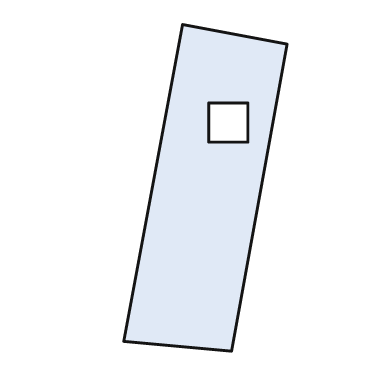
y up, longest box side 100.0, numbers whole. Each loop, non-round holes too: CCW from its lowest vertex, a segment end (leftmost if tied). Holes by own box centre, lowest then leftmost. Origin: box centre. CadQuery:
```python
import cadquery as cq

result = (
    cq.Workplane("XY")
    .moveTo(8.0, -50.0)
    .lineTo(25.0, 44.0)
    .lineTo(-7.0, 50.0)
    .lineTo(-25.0, -47.0)
    .close()
    .moveTo(1.0, 14.0)
    .lineTo(13.0, 14.0)
    .lineTo(13.0, 26.0)
    .lineTo(1.0, 26.0)
    .close()
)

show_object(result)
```